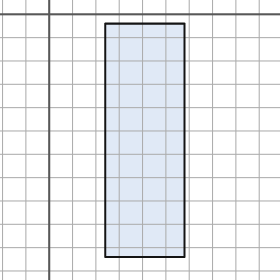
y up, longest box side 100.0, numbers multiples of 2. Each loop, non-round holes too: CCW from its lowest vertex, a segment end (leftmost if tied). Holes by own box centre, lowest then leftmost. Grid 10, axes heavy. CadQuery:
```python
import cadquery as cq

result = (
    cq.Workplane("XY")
    .moveTo(24.0, -104.0)
    .lineTo(58.0, -104.0)
    .lineTo(58.0, -4.0)
    .lineTo(24.0, -4.0)
    .close()
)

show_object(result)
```